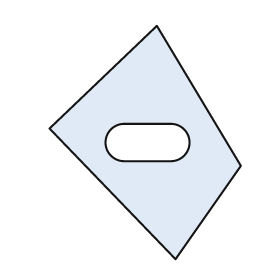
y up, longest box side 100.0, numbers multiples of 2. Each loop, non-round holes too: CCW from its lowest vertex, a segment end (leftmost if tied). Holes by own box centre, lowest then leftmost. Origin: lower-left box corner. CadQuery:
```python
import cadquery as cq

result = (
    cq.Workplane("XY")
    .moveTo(54.0, 0.0)
    .lineTo(82.0, 40.0)
    .lineTo(46.0, 100.0)
    .lineTo(0.0, 56.0)
    .close()
    .moveTo(32.0, 42.0)
    .lineTo(52.0, 42.0)
    .threePointArc((60.0, 50.0), (52.0, 58.0))
    .lineTo(32.0, 58.0)
    .threePointArc((24.0, 50.0), (32.0, 42.0))
    .close()
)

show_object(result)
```